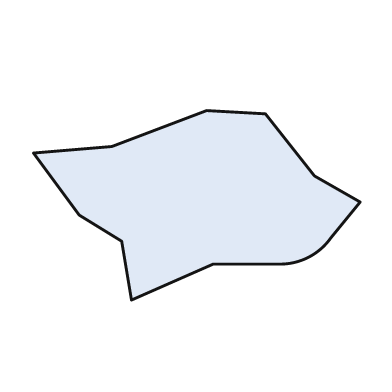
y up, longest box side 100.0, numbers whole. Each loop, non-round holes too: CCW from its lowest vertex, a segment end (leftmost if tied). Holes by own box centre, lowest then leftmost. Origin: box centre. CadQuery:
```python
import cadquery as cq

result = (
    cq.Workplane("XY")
    .moveTo(-20.0, -29.0)
    .lineTo(5.0, -18.0)
    .lineTo(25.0, -18.0)
    .threePointArc((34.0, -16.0), (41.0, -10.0))
    .lineTo(50.0, 1.0)
    .lineTo(36.0, 9.0)
    .lineTo(21.0, 28.0)
    .lineTo(3.0, 29.0)
    .lineTo(-26.0, 18.0)
    .lineTo(-50.0, 16.0)
    .lineTo(-36.0, -3.0)
    .lineTo(-23.0, -11.0)
    .close()
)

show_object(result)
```